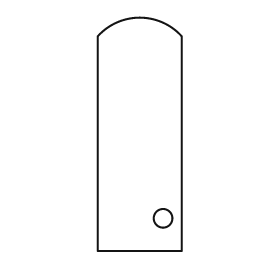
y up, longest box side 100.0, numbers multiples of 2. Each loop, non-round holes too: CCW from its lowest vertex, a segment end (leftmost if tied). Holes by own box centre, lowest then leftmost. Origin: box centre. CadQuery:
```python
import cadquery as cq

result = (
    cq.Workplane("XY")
    .moveTo(-18.0, -50.0)
    .lineTo(18.0, -50.0)
    .lineTo(18.0, 42.0)
    .threePointArc((0.0, 50.0), (-18.0, 42.0))
    .close()
    .moveTo(10.0, -36.0)
    .circle(4.0)
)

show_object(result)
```